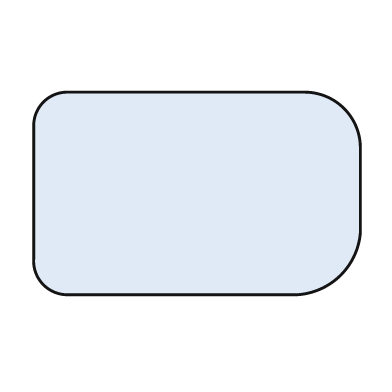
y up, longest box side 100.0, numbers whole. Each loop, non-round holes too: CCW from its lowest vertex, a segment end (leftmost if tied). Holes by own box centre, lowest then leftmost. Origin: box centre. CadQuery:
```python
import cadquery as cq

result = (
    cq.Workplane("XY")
    .moveTo(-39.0, -31.0)
    .lineTo(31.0, -31.0)
    .threePointArc((44.0, -25.0), (50.0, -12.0))
    .lineTo(50.0, 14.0)
    .threePointArc((45.0, 26.0), (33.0, 31.0))
    .lineTo(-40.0, 31.0)
    .threePointArc((-47.0, 28.0), (-50.0, 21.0))
    .lineTo(-50.0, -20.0)
    .threePointArc((-47.0, -28.0), (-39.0, -31.0))
    .close()
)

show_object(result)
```